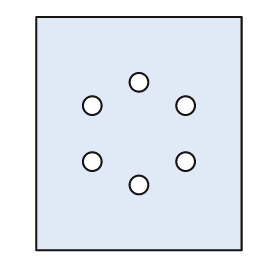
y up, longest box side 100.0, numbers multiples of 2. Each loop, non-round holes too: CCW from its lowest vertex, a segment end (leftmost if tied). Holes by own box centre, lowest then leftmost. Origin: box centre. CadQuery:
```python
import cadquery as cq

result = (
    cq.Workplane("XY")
    .moveTo(-44.0, -50.0)
    .lineTo(44.0, -50.0)
    .lineTo(44.0, 50.0)
    .lineTo(-44.0, 50.0)
    .close()
    .moveTo(0.0, -22.0)
    .circle(4.0)
    .moveTo(-20.0, -12.0)
    .circle(4.0)
    .moveTo(20.0, -12.0)
    .circle(4.0)
    .moveTo(-20.0, 12.0)
    .circle(4.0)
    .moveTo(20.0, 12.0)
    .circle(4.0)
    .moveTo(0.0, 22.0)
    .circle(4.0)
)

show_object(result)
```